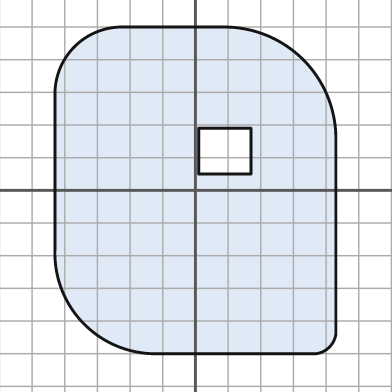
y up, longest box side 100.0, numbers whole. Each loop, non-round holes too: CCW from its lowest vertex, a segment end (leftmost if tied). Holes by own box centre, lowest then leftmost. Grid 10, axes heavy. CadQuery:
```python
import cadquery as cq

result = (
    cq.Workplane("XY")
    .moveTo(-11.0, -50.0)
    .lineTo(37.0, -50.0)
    .threePointArc((41.0, -48.0), (43.0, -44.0))
    .lineTo(43.0, 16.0)
    .threePointArc((33.0, 40.0), (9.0, 50.0))
    .lineTo(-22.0, 50.0)
    .threePointArc((-37.0, 44.0), (-43.0, 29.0))
    .lineTo(-43.0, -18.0)
    .threePointArc((-34.0, -41.0), (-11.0, -50.0))
    .close()
    .moveTo(1.0, 5.0)
    .lineTo(17.0, 5.0)
    .lineTo(17.0, 19.0)
    .lineTo(1.0, 19.0)
    .close()
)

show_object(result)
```